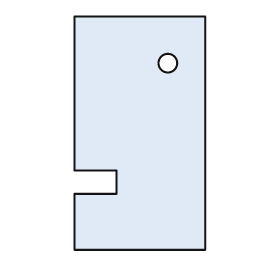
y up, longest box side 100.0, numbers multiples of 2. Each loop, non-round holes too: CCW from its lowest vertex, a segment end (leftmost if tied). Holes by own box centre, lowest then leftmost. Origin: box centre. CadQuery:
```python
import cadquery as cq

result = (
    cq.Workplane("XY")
    .moveTo(-28.0, -50.0)
    .lineTo(28.0, -50.0)
    .lineTo(28.0, 50.0)
    .lineTo(-28.0, 50.0)
    .lineTo(-28.0, -16.0)
    .lineTo(-10.0, -16.0)
    .lineTo(-10.0, -26.0)
    .lineTo(-28.0, -26.0)
    .close()
    .moveTo(12.0, 30.0)
    .circle(4.0)
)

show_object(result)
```